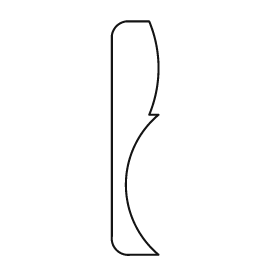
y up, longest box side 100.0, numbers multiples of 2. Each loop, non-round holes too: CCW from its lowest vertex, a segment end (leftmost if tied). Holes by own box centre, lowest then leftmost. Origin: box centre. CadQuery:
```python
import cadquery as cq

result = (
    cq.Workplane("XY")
    .moveTo(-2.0, -50.0)
    .lineTo(10.0, -50.0)
    .threePointArc((-4.0, -20.0), (10.0, 10.0))
    .lineTo(6.0, 10.0)
    .threePointArc((10.0, 30.0), (6.0, 50.0))
    .lineTo(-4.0, 50.0)
    .threePointArc((-8.0, 48.0), (-10.0, 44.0))
    .lineTo(-10.0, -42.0)
    .threePointArc((-8.0, -48.0), (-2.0, -50.0))
    .close()
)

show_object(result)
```